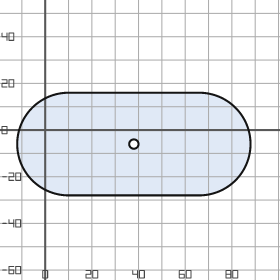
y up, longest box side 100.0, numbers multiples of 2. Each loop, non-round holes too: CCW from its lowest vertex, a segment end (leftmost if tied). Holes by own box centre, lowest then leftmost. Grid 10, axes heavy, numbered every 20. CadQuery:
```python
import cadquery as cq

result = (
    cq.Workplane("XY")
    .moveTo(10.0, -28.0)
    .lineTo(66.0, -28.0)
    .threePointArc((88.0, -6.0), (66.0, 16.0))
    .lineTo(10.0, 16.0)
    .threePointArc((-12.0, -6.0), (10.0, -28.0))
    .close()
    .moveTo(38.0, -6.0)
    .circle(2.0)
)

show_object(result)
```